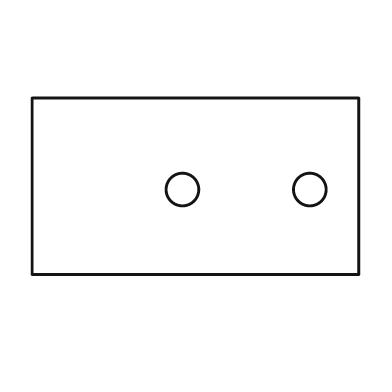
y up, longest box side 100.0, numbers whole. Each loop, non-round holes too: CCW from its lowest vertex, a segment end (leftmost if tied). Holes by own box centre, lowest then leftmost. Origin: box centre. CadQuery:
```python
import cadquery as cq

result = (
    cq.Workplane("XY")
    .moveTo(-50.0, -27.0)
    .lineTo(50.0, -27.0)
    .lineTo(50.0, 27.0)
    .lineTo(-50.0, 27.0)
    .close()
    .moveTo(-4.0, -1.0)
    .circle(5.0)
    .moveTo(35.0, -1.0)
    .circle(5.0)
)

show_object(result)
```